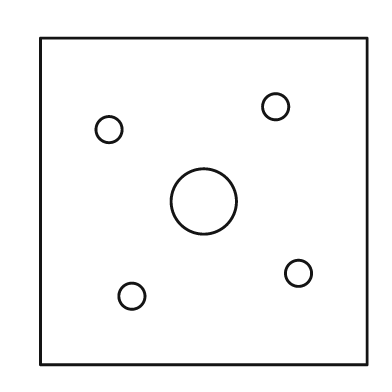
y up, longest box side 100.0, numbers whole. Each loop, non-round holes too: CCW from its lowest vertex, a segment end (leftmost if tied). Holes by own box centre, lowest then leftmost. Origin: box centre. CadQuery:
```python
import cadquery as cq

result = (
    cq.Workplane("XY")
    .moveTo(-50.0, -50.0)
    .lineTo(50.0, -50.0)
    .lineTo(50.0, 50.0)
    .lineTo(-50.0, 50.0)
    .close()
    .moveTo(-22.0, -29.0)
    .circle(4.0)
    .moveTo(29.0, -22.0)
    .circle(4.0)
    .moveTo(0.0, 0.0)
    .circle(10.0)
    .moveTo(-29.0, 22.0)
    .circle(4.0)
    .moveTo(22.0, 29.0)
    .circle(4.0)
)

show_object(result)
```